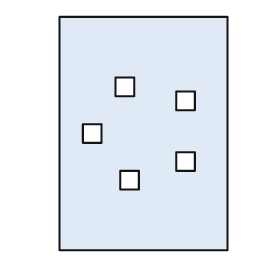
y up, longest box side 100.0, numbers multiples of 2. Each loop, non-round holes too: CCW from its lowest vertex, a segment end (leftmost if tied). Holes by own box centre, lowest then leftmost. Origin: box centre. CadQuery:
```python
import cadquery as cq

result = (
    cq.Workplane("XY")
    .moveTo(-36.0, -50.0)
    .lineTo(36.0, -50.0)
    .lineTo(36.0, 50.0)
    .lineTo(-36.0, 50.0)
    .close()
    .moveTo(-10.0, -24.0)
    .lineTo(-2.0, -24.0)
    .lineTo(-2.0, -16.0)
    .lineTo(-10.0, -16.0)
    .close()
    .moveTo(14.0, -16.0)
    .lineTo(22.0, -16.0)
    .lineTo(22.0, -8.0)
    .lineTo(14.0, -8.0)
    .close()
    .moveTo(-26.0, -4.0)
    .lineTo(-18.0, -4.0)
    .lineTo(-18.0, 4.0)
    .lineTo(-26.0, 4.0)
    .close()
    .moveTo(14.0, 10.0)
    .lineTo(22.0, 10.0)
    .lineTo(22.0, 18.0)
    .lineTo(14.0, 18.0)
    .close()
    .moveTo(-12.0, 16.0)
    .lineTo(-4.0, 16.0)
    .lineTo(-4.0, 24.0)
    .lineTo(-12.0, 24.0)
    .close()
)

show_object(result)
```